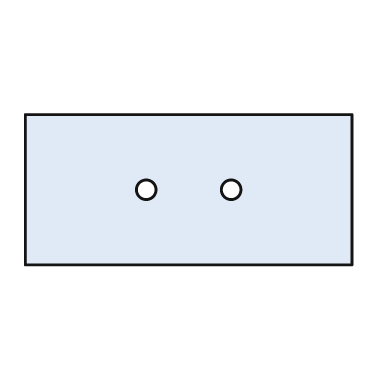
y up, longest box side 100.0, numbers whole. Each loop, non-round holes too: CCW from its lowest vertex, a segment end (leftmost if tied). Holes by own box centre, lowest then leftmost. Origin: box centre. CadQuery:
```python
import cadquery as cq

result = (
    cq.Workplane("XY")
    .moveTo(-50.0, -23.0)
    .lineTo(50.0, -23.0)
    .lineTo(50.0, 23.0)
    .lineTo(-50.0, 23.0)
    .close()
    .moveTo(-13.0, 0.0)
    .circle(3.0)
    .moveTo(13.0, 0.0)
    .circle(3.0)
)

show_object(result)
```